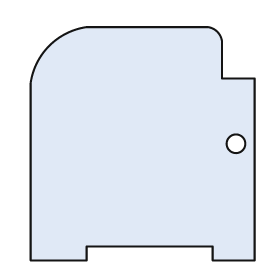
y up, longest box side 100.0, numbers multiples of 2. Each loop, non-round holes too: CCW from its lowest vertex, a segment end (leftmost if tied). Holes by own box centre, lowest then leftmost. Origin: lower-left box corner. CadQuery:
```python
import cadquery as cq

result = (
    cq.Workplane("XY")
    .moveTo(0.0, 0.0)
    .lineTo(24.0, 0.0)
    .lineTo(24.0, 6.0)
    .lineTo(78.0, 6.0)
    .lineTo(78.0, 0.0)
    .lineTo(96.0, 0.0)
    .lineTo(96.0, 78.0)
    .lineTo(82.0, 78.0)
    .lineTo(82.0, 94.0)
    .threePointArc((80.0, 98.0), (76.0, 100.0))
    .lineTo(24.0, 100.0)
    .threePointArc((8.0, 92.0), (0.0, 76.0))
    .close()
    .moveTo(88.0, 50.0)
    .circle(4.0)
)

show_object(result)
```